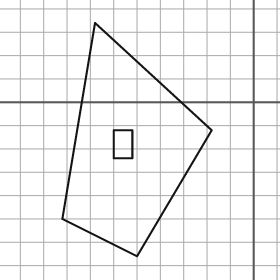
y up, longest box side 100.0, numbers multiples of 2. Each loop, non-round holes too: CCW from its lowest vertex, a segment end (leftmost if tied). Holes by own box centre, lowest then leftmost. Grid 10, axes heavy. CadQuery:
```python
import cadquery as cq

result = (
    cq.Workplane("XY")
    .moveTo(-50.0, -66.0)
    .lineTo(-18.0, -12.0)
    .lineTo(-68.0, 34.0)
    .lineTo(-82.0, -50.0)
    .close()
    .moveTo(-60.0, -24.0)
    .lineTo(-52.0, -24.0)
    .lineTo(-52.0, -12.0)
    .lineTo(-60.0, -12.0)
    .close()
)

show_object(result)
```